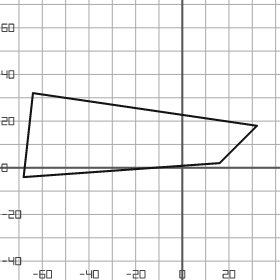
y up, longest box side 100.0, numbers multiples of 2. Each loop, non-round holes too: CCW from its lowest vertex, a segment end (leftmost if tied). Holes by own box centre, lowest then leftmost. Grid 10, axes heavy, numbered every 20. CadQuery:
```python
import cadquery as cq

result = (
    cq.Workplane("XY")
    .moveTo(-68.0, -4.0)
    .lineTo(16.0, 2.0)
    .lineTo(32.0, 18.0)
    .lineTo(-64.0, 32.0)
    .close()
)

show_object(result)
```